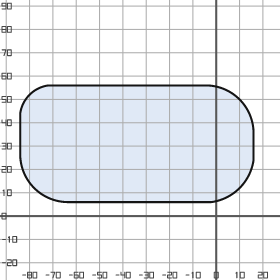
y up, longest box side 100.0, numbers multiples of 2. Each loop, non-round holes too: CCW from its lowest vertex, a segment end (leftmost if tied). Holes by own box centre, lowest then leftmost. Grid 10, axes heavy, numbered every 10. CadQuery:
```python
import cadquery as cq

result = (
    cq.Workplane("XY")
    .moveTo(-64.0, 6.0)
    .lineTo(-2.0, 6.0)
    .threePointArc((10.0, 12.0), (16.0, 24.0))
    .lineTo(16.0, 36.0)
    .threePointArc((10.0, 50.0), (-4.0, 56.0))
    .lineTo(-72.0, 56.0)
    .threePointArc((-80.0, 52.0), (-84.0, 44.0))
    .lineTo(-84.0, 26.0)
    .threePointArc((-78.0, 12.0), (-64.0, 6.0))
    .close()
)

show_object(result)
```